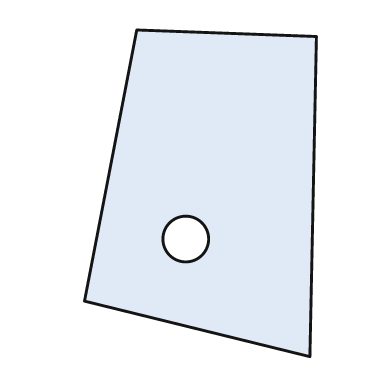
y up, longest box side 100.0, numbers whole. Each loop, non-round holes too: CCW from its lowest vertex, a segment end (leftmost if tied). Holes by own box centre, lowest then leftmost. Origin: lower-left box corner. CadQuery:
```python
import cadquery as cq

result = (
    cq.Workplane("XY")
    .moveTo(69.0, 0.0)
    .lineTo(71.0, 98.0)
    .lineTo(16.0, 100.0)
    .lineTo(0.0, 17.0)
    .close()
    .moveTo(31.0, 36.0)
    .circle(7.0)
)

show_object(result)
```